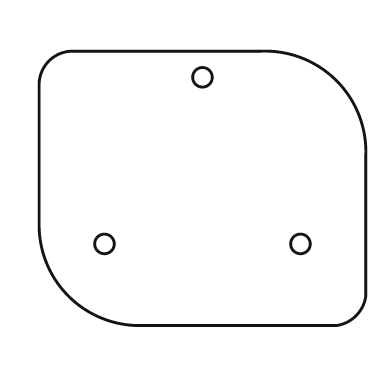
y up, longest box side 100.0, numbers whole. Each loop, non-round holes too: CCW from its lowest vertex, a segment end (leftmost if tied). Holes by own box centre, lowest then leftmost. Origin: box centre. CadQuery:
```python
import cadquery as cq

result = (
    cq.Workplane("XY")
    .moveTo(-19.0, -42.0)
    .lineTo(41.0, -42.0)
    .threePointArc((47.0, -39.0), (50.0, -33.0))
    .lineTo(50.0, 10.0)
    .threePointArc((41.0, 33.0), (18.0, 42.0))
    .lineTo(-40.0, 42.0)
    .threePointArc((-47.0, 39.0), (-50.0, 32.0))
    .lineTo(-50.0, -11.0)
    .threePointArc((-41.0, -33.0), (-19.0, -42.0))
    .close()
    .moveTo(-30.0, -17.0)
    .circle(3.0)
    .moveTo(30.0, -17.0)
    .circle(3.0)
    .moveTo(0.0, 34.0)
    .circle(3.0)
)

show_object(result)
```